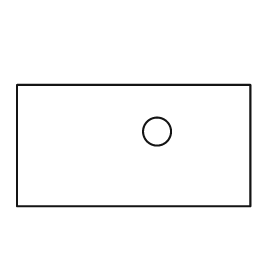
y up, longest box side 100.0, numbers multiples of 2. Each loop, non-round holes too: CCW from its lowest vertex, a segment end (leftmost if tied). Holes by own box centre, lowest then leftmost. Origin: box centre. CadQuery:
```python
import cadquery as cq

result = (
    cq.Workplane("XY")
    .moveTo(-50.0, -26.0)
    .lineTo(50.0, -26.0)
    .lineTo(50.0, 26.0)
    .lineTo(-50.0, 26.0)
    .close()
    .moveTo(10.0, 6.0)
    .circle(6.0)
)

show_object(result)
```